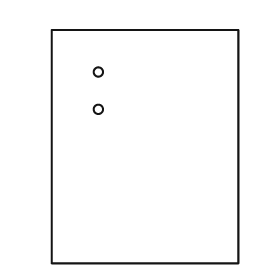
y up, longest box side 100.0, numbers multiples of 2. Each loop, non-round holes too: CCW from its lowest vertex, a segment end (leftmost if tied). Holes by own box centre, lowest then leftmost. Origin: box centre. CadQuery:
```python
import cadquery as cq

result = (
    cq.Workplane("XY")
    .moveTo(-40.0, -50.0)
    .lineTo(40.0, -50.0)
    .lineTo(40.0, 50.0)
    .lineTo(-40.0, 50.0)
    .close()
    .moveTo(-20.0, 16.0)
    .circle(2.0)
    .moveTo(-20.0, 32.0)
    .circle(2.0)
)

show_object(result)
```